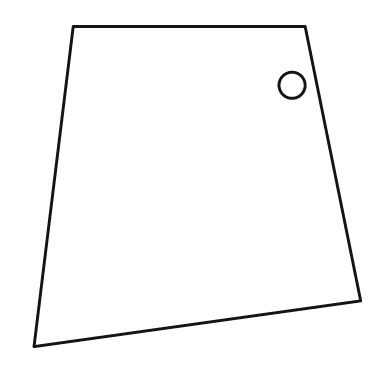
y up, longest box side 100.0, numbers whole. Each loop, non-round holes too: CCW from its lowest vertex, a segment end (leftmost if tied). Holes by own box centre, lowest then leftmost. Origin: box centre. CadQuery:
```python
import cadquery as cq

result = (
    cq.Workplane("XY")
    .moveTo(-50.0, -49.0)
    .lineTo(50.0, -35.0)
    .lineTo(33.0, 49.0)
    .lineTo(-38.0, 49.0)
    .close()
    .moveTo(29.0, 31.0)
    .circle(4.0)
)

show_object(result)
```